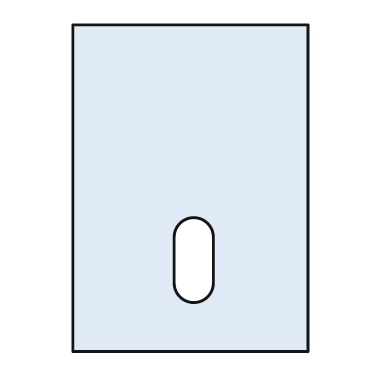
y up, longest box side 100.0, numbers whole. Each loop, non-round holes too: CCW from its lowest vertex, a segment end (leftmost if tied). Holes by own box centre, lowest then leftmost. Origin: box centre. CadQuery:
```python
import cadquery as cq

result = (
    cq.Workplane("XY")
    .moveTo(-36.0, -50.0)
    .lineTo(36.0, -50.0)
    .lineTo(36.0, 50.0)
    .lineTo(-36.0, 50.0)
    .close()
    .moveTo(-5.0, -29.0)
    .threePointArc((1.0, -35.0), (7.0, -29.0))
    .lineTo(7.0, -15.0)
    .threePointArc((1.0, -9.0), (-5.0, -15.0))
    .close()
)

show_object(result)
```